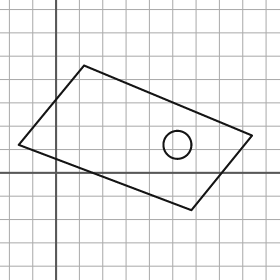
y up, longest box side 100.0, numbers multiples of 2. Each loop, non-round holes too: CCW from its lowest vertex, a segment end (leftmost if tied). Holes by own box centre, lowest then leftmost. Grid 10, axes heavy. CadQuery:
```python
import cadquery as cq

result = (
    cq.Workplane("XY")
    .moveTo(58.0, -16.0)
    .lineTo(84.0, 16.0)
    .lineTo(12.0, 46.0)
    .lineTo(-16.0, 12.0)
    .close()
    .moveTo(52.0, 12.0)
    .circle(6.0)
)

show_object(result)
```